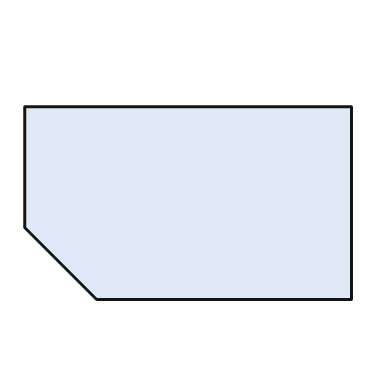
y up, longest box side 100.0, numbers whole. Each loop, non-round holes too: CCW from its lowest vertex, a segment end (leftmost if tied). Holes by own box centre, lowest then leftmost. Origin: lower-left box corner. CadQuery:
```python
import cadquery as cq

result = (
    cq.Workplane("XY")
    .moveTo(22.0, 0.0)
    .lineTo(100.0, 0.0)
    .lineTo(100.0, 59.0)
    .lineTo(0.0, 59.0)
    .lineTo(0.0, 22.0)
    .close()
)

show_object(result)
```